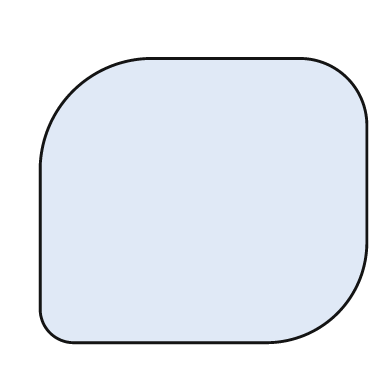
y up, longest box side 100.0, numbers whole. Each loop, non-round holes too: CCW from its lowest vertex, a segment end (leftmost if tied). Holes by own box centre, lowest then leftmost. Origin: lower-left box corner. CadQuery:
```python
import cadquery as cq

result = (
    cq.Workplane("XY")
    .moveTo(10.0, 0.0)
    .lineTo(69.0, 0.0)
    .threePointArc((91.0, 9.0), (100.0, 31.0))
    .lineTo(100.0, 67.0)
    .threePointArc((94.0, 81.0), (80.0, 87.0))
    .lineTo(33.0, 87.0)
    .threePointArc((10.0, 77.0), (0.0, 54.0))
    .lineTo(0.0, 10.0)
    .threePointArc((3.0, 3.0), (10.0, 0.0))
    .close()
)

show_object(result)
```